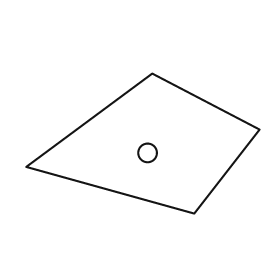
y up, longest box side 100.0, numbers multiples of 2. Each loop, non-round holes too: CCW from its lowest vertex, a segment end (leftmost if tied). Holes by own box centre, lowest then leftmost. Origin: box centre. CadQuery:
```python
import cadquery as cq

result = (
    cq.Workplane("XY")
    .moveTo(22.0, -30.0)
    .lineTo(50.0, 6.0)
    .lineTo(4.0, 30.0)
    .lineTo(-50.0, -10.0)
    .close()
    .moveTo(2.0, -4.0)
    .circle(4.0)
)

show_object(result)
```